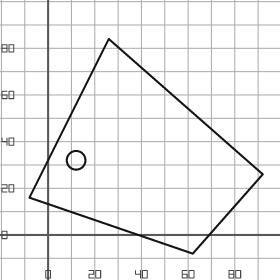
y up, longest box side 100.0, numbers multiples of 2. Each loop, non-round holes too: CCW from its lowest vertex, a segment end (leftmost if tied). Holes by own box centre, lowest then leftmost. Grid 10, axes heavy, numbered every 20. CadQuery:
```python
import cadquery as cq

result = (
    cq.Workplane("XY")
    .moveTo(62.0, -8.0)
    .lineTo(92.0, 26.0)
    .lineTo(26.0, 84.0)
    .lineTo(-8.0, 16.0)
    .close()
    .moveTo(12.0, 32.0)
    .circle(4.0)
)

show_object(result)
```